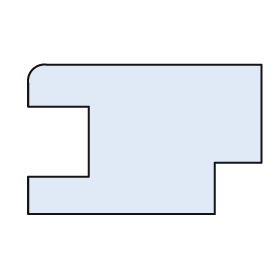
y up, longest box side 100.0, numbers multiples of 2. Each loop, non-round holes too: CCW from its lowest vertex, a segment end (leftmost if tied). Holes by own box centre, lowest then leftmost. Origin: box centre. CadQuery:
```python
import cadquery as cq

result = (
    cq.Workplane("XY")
    .moveTo(-50.0, -32.0)
    .lineTo(30.0, -32.0)
    .lineTo(30.0, -10.0)
    .lineTo(50.0, -10.0)
    .lineTo(50.0, 32.0)
    .lineTo(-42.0, 32.0)
    .threePointArc((-48.0, 30.0), (-50.0, 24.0))
    .lineTo(-50.0, 14.0)
    .lineTo(-24.0, 14.0)
    .lineTo(-24.0, -16.0)
    .lineTo(-50.0, -16.0)
    .close()
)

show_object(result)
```